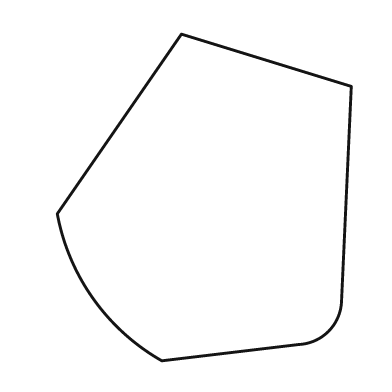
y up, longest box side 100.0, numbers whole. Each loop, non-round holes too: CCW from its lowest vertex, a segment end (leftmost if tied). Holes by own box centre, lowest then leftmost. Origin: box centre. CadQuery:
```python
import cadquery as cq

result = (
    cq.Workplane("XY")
    .moveTo(-13.0, -50.0)
    .lineTo(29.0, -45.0)
    .threePointArc((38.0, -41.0), (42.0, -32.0))
    .lineTo(45.0, 34.0)
    .lineTo(-7.0, 50.0)
    .lineTo(-45.0, -5.0)
    .threePointArc((-34.0, -31.0), (-13.0, -50.0))
    .close()
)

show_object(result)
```